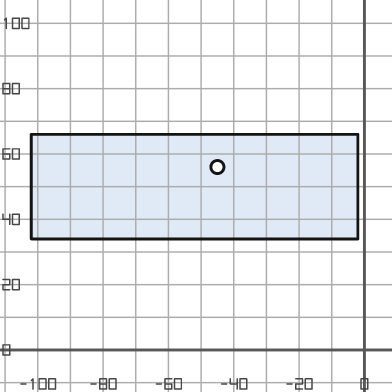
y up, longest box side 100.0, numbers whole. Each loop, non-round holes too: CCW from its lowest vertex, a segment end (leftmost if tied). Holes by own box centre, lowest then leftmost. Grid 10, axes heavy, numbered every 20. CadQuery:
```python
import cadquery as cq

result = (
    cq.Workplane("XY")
    .moveTo(-102.0, 34.0)
    .lineTo(-2.0, 34.0)
    .lineTo(-2.0, 66.0)
    .lineTo(-102.0, 66.0)
    .close()
    .moveTo(-45.0, 56.0)
    .circle(2.0)
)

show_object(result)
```